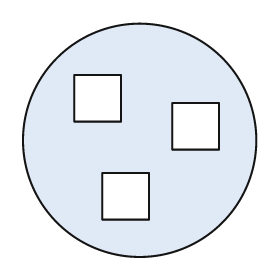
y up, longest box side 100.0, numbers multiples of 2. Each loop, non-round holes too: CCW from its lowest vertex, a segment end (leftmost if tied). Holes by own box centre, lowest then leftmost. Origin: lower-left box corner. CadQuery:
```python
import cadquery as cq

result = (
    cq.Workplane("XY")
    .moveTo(50.0, 50.0)
    .circle(50.0)
    .moveTo(34.0, 16.0)
    .lineTo(54.0, 16.0)
    .lineTo(54.0, 36.0)
    .lineTo(34.0, 36.0)
    .close()
    .moveTo(64.0, 46.0)
    .lineTo(84.0, 46.0)
    .lineTo(84.0, 66.0)
    .lineTo(64.0, 66.0)
    .close()
    .moveTo(22.0, 58.0)
    .lineTo(42.0, 58.0)
    .lineTo(42.0, 78.0)
    .lineTo(22.0, 78.0)
    .close()
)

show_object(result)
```